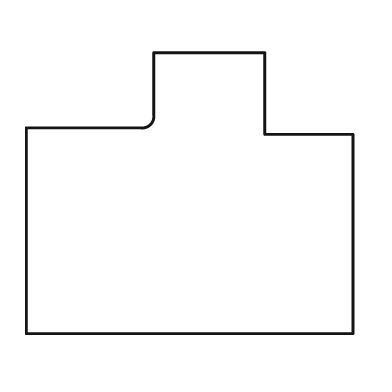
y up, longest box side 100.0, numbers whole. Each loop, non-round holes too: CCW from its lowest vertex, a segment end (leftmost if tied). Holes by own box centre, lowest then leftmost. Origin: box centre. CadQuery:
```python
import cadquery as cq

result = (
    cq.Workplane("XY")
    .moveTo(-50.0, -43.0)
    .lineTo(50.0, -43.0)
    .lineTo(50.0, 18.0)
    .lineTo(23.0, 18.0)
    .lineTo(23.0, 43.0)
    .lineTo(-11.0, 43.0)
    .lineTo(-11.0, 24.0)
    .threePointArc((-12.0, 21.0), (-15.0, 20.0))
    .lineTo(-50.0, 20.0)
    .close()
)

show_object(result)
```